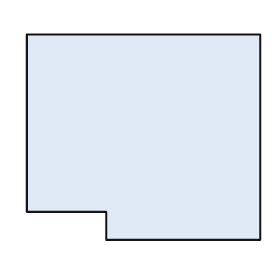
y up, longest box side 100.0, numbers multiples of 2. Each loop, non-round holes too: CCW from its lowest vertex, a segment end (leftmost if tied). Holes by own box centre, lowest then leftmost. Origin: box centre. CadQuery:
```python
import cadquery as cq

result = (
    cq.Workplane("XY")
    .moveTo(-16.0, -44.0)
    .lineTo(50.0, -44.0)
    .lineTo(50.0, 44.0)
    .lineTo(-50.0, 44.0)
    .lineTo(-50.0, -32.0)
    .lineTo(-16.0, -32.0)
    .close()
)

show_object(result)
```